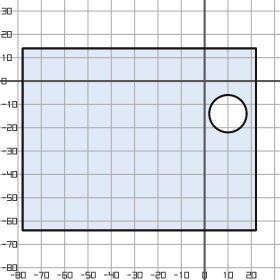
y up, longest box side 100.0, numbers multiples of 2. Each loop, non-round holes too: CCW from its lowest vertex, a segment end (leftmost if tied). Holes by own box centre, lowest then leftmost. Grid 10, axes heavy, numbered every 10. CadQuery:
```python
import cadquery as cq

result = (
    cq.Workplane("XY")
    .moveTo(-78.0, -64.0)
    .lineTo(22.0, -64.0)
    .lineTo(22.0, 14.0)
    .lineTo(-78.0, 14.0)
    .close()
    .moveTo(10.0, -14.0)
    .circle(8.0)
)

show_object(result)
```